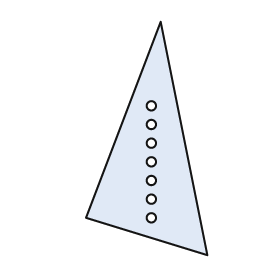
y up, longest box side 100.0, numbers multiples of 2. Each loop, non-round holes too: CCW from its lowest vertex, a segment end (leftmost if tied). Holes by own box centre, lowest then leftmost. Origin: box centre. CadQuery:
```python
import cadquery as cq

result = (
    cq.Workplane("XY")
    .moveTo(26.0, -50.0)
    .lineTo(6.0, 50.0)
    .lineTo(-26.0, -34.0)
    .close()
    .moveTo(2.0, -34.0)
    .circle(2.0)
    .moveTo(2.0, -26.0)
    .circle(2.0)
    .moveTo(2.0, -18.0)
    .circle(2.0)
    .moveTo(2.0, -10.0)
    .circle(2.0)
    .moveTo(2.0, -2.0)
    .circle(2.0)
    .moveTo(2.0, 6.0)
    .circle(2.0)
    .moveTo(2.0, 14.0)
    .circle(2.0)
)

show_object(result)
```